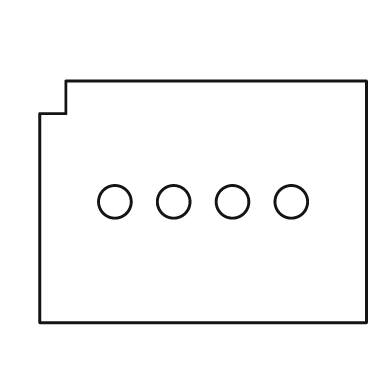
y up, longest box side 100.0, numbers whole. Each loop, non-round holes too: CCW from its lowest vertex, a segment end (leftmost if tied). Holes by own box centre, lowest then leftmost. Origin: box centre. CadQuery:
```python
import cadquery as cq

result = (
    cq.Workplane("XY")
    .moveTo(-50.0, -37.0)
    .lineTo(50.0, -37.0)
    .lineTo(50.0, 37.0)
    .lineTo(-42.0, 37.0)
    .lineTo(-42.0, 27.0)
    .lineTo(-50.0, 27.0)
    .close()
    .moveTo(-27.0, 0.0)
    .circle(5.0)
    .moveTo(-9.0, 0.0)
    .circle(5.0)
    .moveTo(9.0, 0.0)
    .circle(5.0)
    .moveTo(27.0, 0.0)
    .circle(5.0)
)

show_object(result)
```